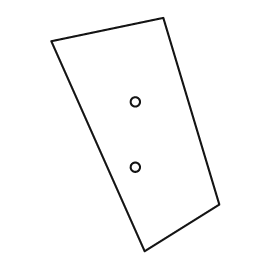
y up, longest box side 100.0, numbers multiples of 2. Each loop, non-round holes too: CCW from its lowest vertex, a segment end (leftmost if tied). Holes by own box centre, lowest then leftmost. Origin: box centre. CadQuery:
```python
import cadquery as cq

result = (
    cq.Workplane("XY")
    .moveTo(4.0, -50.0)
    .lineTo(36.0, -30.0)
    .lineTo(12.0, 50.0)
    .lineTo(-36.0, 40.0)
    .close()
    .moveTo(0.0, -14.0)
    .circle(2.0)
    .moveTo(0.0, 14.0)
    .circle(2.0)
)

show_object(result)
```